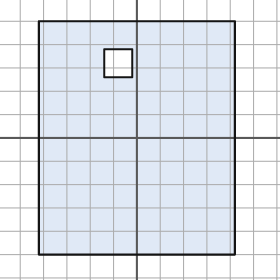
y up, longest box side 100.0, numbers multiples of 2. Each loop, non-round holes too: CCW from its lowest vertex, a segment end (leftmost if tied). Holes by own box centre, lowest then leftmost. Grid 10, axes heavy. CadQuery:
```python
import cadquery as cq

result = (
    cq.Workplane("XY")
    .moveTo(-42.0, -50.0)
    .lineTo(42.0, -50.0)
    .lineTo(42.0, 50.0)
    .lineTo(-42.0, 50.0)
    .close()
    .moveTo(-14.0, 26.0)
    .lineTo(-2.0, 26.0)
    .lineTo(-2.0, 38.0)
    .lineTo(-14.0, 38.0)
    .close()
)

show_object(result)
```